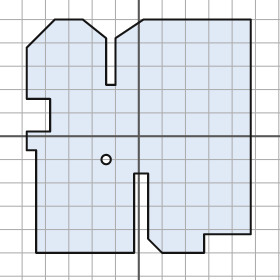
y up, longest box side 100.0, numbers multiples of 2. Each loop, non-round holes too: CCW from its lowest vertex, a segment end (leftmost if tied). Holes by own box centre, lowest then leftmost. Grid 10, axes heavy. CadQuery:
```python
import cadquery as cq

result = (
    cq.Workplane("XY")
    .moveTo(-44.0, -50.0)
    .lineTo(-2.0, -50.0)
    .lineTo(-2.0, -16.0)
    .lineTo(4.0, -16.0)
    .lineTo(4.0, -44.0)
    .lineTo(10.0, -50.0)
    .lineTo(28.0, -50.0)
    .lineTo(28.0, -42.0)
    .lineTo(48.0, -42.0)
    .lineTo(48.0, 50.0)
    .lineTo(2.0, 50.0)
    .lineTo(-10.0, 42.0)
    .lineTo(-10.0, 22.0)
    .lineTo(-14.0, 22.0)
    .lineTo(-14.0, 42.0)
    .lineTo(-24.0, 50.0)
    .lineTo(-36.0, 50.0)
    .lineTo(-48.0, 38.0)
    .lineTo(-48.0, 16.0)
    .lineTo(-38.0, 16.0)
    .lineTo(-38.0, 2.0)
    .lineTo(-48.0, 2.0)
    .lineTo(-48.0, -6.0)
    .lineTo(-44.0, -6.0)
    .close()
    .moveTo(-14.0, -10.0)
    .circle(2.0)
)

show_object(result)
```